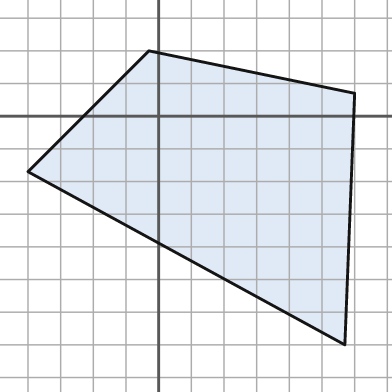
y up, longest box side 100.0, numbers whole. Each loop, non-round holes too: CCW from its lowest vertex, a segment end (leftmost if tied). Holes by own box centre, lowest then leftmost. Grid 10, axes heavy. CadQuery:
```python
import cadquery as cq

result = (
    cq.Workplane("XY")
    .moveTo(57.0, -70.0)
    .lineTo(60.0, 7.0)
    .lineTo(-3.0, 20.0)
    .lineTo(-40.0, -17.0)
    .close()
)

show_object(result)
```